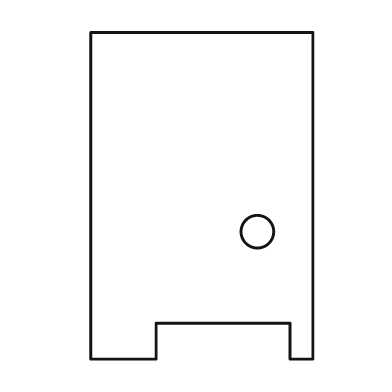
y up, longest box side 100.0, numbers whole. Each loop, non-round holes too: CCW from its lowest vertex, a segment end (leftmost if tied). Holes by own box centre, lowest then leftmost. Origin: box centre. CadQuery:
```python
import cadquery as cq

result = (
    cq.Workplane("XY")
    .moveTo(-34.0, -50.0)
    .lineTo(-14.0, -50.0)
    .lineTo(-14.0, -39.0)
    .lineTo(27.0, -39.0)
    .lineTo(27.0, -50.0)
    .lineTo(34.0, -50.0)
    .lineTo(34.0, 50.0)
    .lineTo(-34.0, 50.0)
    .close()
    .moveTo(17.0, -11.0)
    .circle(5.0)
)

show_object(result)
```